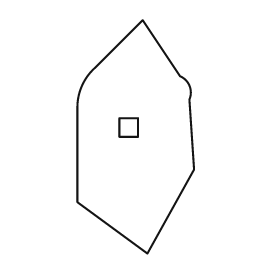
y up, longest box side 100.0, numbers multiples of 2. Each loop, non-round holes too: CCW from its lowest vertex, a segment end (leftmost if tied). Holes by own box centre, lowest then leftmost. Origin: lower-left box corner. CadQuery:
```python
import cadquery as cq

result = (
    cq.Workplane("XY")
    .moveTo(30.0, 0.0)
    .lineTo(50.0, 36.0)
    .lineTo(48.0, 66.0)
    .threePointArc((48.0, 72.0), (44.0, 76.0))
    .lineTo(28.0, 100.0)
    .lineTo(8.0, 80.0)
    .threePointArc((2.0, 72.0), (0.0, 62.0))
    .lineTo(0.0, 22.0)
    .close()
    .moveTo(18.0, 50.0)
    .lineTo(26.0, 50.0)
    .lineTo(26.0, 58.0)
    .lineTo(18.0, 58.0)
    .close()
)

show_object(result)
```